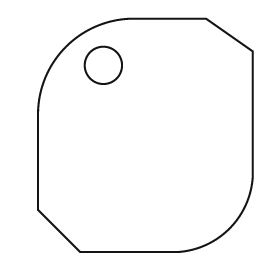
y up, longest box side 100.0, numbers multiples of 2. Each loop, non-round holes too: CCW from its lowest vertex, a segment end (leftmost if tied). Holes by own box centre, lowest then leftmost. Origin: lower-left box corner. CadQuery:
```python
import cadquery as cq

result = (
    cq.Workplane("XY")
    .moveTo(18.0, 0.0)
    .lineTo(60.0, 0.0)
    .threePointArc((82.0, 10.0), (92.0, 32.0))
    .lineTo(92.0, 86.0)
    .lineTo(72.0, 100.0)
    .lineTo(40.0, 100.0)
    .threePointArc((12.0, 88.0), (0.0, 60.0))
    .lineTo(0.0, 18.0)
    .close()
    .moveTo(28.0, 80.0)
    .circle(8.0)
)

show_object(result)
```